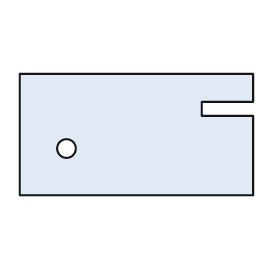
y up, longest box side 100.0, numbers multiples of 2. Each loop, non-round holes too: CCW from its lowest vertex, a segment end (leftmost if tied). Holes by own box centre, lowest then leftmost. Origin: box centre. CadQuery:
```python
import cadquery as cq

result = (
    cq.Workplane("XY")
    .moveTo(-50.0, -26.0)
    .lineTo(50.0, -26.0)
    .lineTo(50.0, 8.0)
    .lineTo(28.0, 8.0)
    .lineTo(28.0, 14.0)
    .lineTo(50.0, 14.0)
    .lineTo(50.0, 26.0)
    .lineTo(-50.0, 26.0)
    .close()
    .moveTo(-30.0, -6.0)
    .circle(4.0)
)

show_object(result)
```